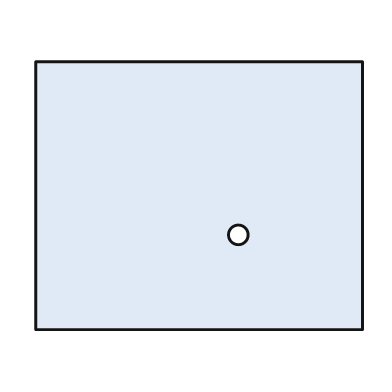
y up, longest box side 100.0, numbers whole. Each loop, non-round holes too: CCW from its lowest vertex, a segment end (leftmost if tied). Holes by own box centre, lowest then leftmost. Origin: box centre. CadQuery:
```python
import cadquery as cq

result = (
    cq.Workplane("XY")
    .moveTo(-50.0, -41.0)
    .lineTo(50.0, -41.0)
    .lineTo(50.0, 41.0)
    .lineTo(-50.0, 41.0)
    .close()
    .moveTo(12.0, -12.0)
    .circle(3.0)
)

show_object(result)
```